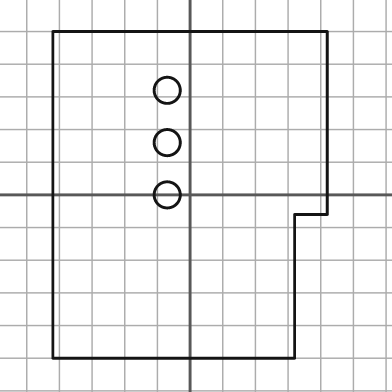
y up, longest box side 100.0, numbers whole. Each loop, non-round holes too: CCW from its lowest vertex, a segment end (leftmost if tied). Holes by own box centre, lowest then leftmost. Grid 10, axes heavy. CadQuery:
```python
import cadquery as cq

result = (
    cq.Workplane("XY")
    .moveTo(-42.0, -50.0)
    .lineTo(32.0, -50.0)
    .lineTo(32.0, -6.0)
    .lineTo(42.0, -6.0)
    .lineTo(42.0, 50.0)
    .lineTo(-42.0, 50.0)
    .close()
    .moveTo(-7.0, 0.0)
    .circle(4.0)
    .moveTo(-7.0, 16.0)
    .circle(4.0)
    .moveTo(-7.0, 32.0)
    .circle(4.0)
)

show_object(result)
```